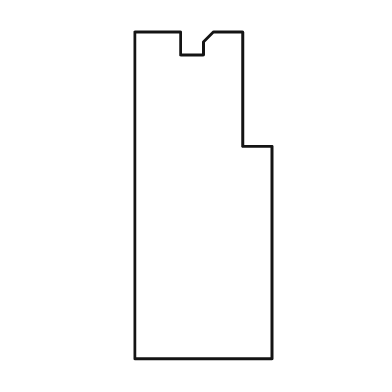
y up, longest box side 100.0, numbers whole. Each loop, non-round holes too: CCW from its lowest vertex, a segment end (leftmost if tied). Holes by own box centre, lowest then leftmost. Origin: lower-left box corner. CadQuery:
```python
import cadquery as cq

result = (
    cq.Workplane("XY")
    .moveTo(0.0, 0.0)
    .lineTo(42.0, 0.0)
    .lineTo(42.0, 65.0)
    .lineTo(33.0, 65.0)
    .lineTo(33.0, 100.0)
    .lineTo(24.0, 100.0)
    .lineTo(21.0, 97.0)
    .lineTo(21.0, 93.0)
    .lineTo(14.0, 93.0)
    .lineTo(14.0, 100.0)
    .lineTo(0.0, 100.0)
    .close()
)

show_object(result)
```